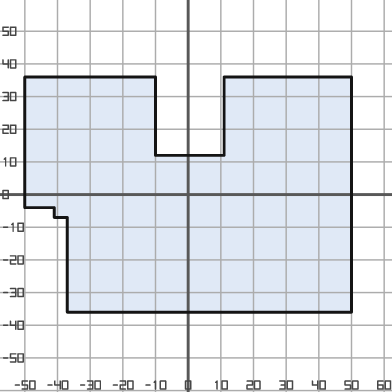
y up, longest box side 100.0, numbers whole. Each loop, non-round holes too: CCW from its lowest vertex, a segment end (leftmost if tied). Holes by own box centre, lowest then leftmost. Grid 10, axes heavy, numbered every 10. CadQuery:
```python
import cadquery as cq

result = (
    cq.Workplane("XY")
    .moveTo(-37.0, -36.0)
    .lineTo(50.0, -36.0)
    .lineTo(50.0, 36.0)
    .lineTo(11.0, 36.0)
    .lineTo(11.0, 12.0)
    .lineTo(-10.0, 12.0)
    .lineTo(-10.0, 36.0)
    .lineTo(-50.0, 36.0)
    .lineTo(-50.0, -4.0)
    .lineTo(-41.0, -4.0)
    .lineTo(-41.0, -7.0)
    .lineTo(-37.0, -7.0)
    .close()
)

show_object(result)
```